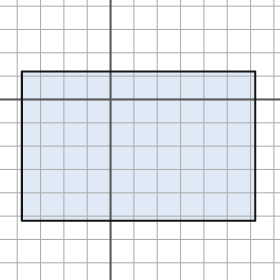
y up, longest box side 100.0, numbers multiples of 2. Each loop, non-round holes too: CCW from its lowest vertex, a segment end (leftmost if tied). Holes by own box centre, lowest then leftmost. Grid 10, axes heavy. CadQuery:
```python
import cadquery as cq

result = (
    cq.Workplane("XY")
    .moveTo(-38.0, -52.0)
    .lineTo(62.0, -52.0)
    .lineTo(62.0, 12.0)
    .lineTo(-38.0, 12.0)
    .close()
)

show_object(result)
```